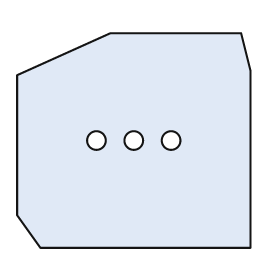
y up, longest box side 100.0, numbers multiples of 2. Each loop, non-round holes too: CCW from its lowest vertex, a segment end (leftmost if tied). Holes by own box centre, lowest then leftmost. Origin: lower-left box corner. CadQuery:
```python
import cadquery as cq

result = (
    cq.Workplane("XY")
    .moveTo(10.0, 0.0)
    .lineTo(100.0, 0.0)
    .lineTo(100.0, 76.0)
    .lineTo(96.0, 92.0)
    .lineTo(40.0, 92.0)
    .lineTo(0.0, 74.0)
    .lineTo(0.0, 14.0)
    .close()
    .moveTo(34.0, 46.0)
    .circle(4.0)
    .moveTo(50.0, 46.0)
    .circle(4.0)
    .moveTo(66.0, 46.0)
    .circle(4.0)
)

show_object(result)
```